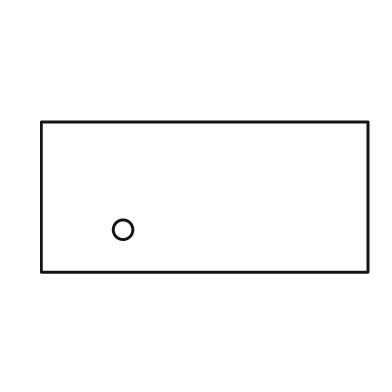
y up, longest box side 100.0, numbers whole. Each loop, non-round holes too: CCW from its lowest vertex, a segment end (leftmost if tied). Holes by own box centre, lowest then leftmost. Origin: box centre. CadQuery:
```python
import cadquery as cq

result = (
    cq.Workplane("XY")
    .moveTo(-50.0, -23.0)
    .lineTo(50.0, -23.0)
    .lineTo(50.0, 23.0)
    .lineTo(-50.0, 23.0)
    .close()
    .moveTo(-25.0, -10.0)
    .circle(3.0)
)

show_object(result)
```